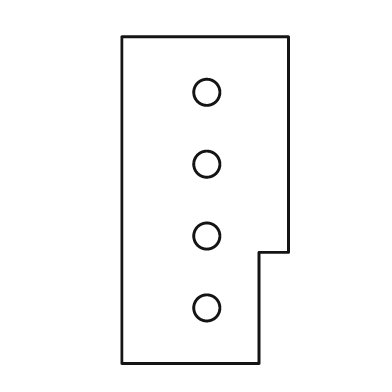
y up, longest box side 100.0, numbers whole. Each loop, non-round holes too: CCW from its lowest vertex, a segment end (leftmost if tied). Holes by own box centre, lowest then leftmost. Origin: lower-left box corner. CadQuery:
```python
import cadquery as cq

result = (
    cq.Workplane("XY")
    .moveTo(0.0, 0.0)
    .lineTo(42.0, 0.0)
    .lineTo(42.0, 34.0)
    .lineTo(51.0, 34.0)
    .lineTo(51.0, 100.0)
    .lineTo(0.0, 100.0)
    .close()
    .moveTo(26.0, 17.0)
    .circle(4.0)
    .moveTo(26.0, 39.0)
    .circle(4.0)
    .moveTo(26.0, 61.0)
    .circle(4.0)
    .moveTo(26.0, 83.0)
    .circle(4.0)
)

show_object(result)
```